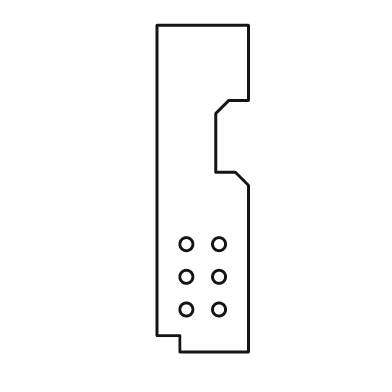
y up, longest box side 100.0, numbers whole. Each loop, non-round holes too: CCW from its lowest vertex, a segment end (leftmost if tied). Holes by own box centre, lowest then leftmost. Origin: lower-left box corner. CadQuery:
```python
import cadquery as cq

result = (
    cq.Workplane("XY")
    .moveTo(7.0, 0.0)
    .lineTo(28.0, 0.0)
    .lineTo(28.0, 51.0)
    .lineTo(24.0, 55.0)
    .lineTo(18.0, 55.0)
    .lineTo(18.0, 73.0)
    .lineTo(22.0, 77.0)
    .lineTo(28.0, 77.0)
    .lineTo(28.0, 100.0)
    .lineTo(0.0, 100.0)
    .lineTo(0.0, 5.0)
    .lineTo(7.0, 5.0)
    .close()
    .moveTo(9.0, 13.0)
    .circle(2.0)
    .moveTo(19.0, 13.0)
    .circle(2.0)
    .moveTo(9.0, 23.0)
    .circle(2.0)
    .moveTo(19.0, 23.0)
    .circle(2.0)
    .moveTo(9.0, 33.0)
    .circle(2.0)
    .moveTo(19.0, 33.0)
    .circle(2.0)
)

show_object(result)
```